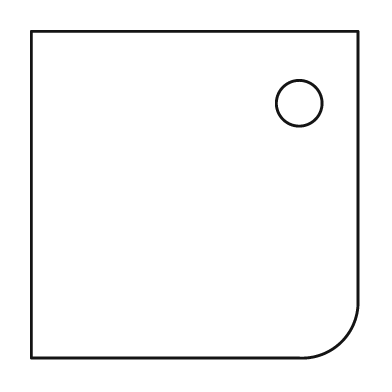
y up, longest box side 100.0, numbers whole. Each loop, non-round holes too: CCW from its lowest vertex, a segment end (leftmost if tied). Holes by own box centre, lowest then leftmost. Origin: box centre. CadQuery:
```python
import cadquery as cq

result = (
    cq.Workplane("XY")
    .moveTo(-50.0, -50.0)
    .lineTo(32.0, -50.0)
    .threePointArc((45.0, -45.0), (50.0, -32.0))
    .lineTo(50.0, 50.0)
    .lineTo(-50.0, 50.0)
    .close()
    .moveTo(32.0, 28.0)
    .circle(7.0)
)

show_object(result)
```